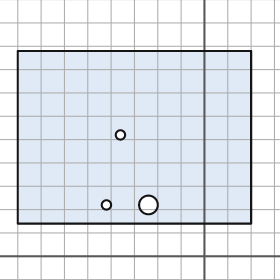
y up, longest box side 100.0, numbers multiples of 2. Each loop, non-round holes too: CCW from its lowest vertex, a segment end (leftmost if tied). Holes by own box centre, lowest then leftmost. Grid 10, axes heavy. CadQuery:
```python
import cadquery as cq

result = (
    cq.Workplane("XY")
    .moveTo(-80.0, 14.0)
    .lineTo(20.0, 14.0)
    .lineTo(20.0, 88.0)
    .lineTo(-80.0, 88.0)
    .close()
    .moveTo(-42.0, 22.0)
    .circle(2.0)
    .moveTo(-24.0, 22.0)
    .circle(4.0)
    .moveTo(-36.0, 52.0)
    .circle(2.0)
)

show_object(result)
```